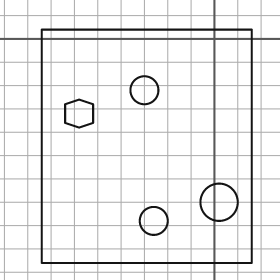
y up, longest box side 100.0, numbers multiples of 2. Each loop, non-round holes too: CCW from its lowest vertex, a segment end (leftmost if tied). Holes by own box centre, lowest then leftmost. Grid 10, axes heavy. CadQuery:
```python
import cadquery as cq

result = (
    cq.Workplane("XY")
    .moveTo(-74.0, -96.0)
    .lineTo(16.0, -96.0)
    .lineTo(16.0, 4.0)
    .lineTo(-74.0, 4.0)
    .close()
    .moveTo(-26.0, -78.0)
    .circle(6.0)
    .moveTo(2.0, -70.0)
    .circle(8.0)
    .moveTo(-58.0, -38.0)
    .lineTo(-52.0, -36.0)
    .lineTo(-52.0, -28.0)
    .lineTo(-58.0, -26.0)
    .lineTo(-64.0, -28.0)
    .lineTo(-64.0, -36.0)
    .close()
    .moveTo(-30.0, -22.0)
    .circle(6.0)
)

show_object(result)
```